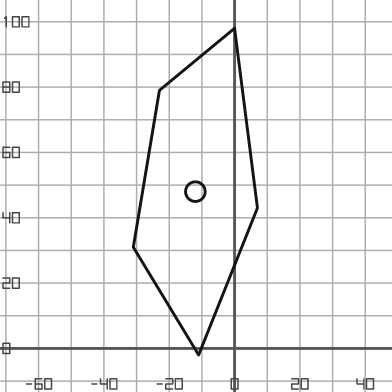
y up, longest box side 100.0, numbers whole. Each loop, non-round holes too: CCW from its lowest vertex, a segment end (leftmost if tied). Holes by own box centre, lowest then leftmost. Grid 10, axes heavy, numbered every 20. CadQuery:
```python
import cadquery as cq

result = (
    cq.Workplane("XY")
    .moveTo(-11.0, -2.0)
    .lineTo(7.0, 43.0)
    .lineTo(0.0, 98.0)
    .lineTo(-23.0, 79.0)
    .lineTo(-31.0, 31.0)
    .close()
    .moveTo(-12.0, 48.0)
    .circle(3.0)
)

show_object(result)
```